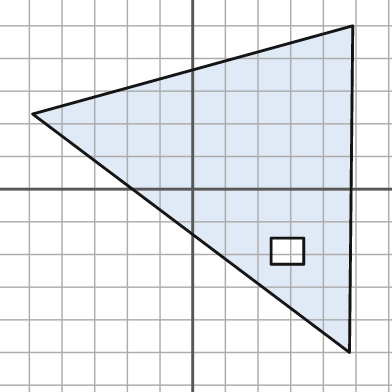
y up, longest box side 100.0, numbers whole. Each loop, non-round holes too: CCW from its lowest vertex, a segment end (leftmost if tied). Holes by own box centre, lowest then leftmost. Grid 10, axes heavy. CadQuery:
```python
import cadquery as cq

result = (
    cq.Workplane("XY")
    .moveTo(48.0, -50.0)
    .lineTo(49.0, 50.0)
    .lineTo(-49.0, 23.0)
    .close()
    .moveTo(24.0, -23.0)
    .lineTo(34.0, -23.0)
    .lineTo(34.0, -15.0)
    .lineTo(24.0, -15.0)
    .close()
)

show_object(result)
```